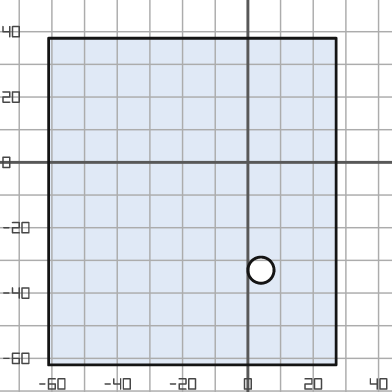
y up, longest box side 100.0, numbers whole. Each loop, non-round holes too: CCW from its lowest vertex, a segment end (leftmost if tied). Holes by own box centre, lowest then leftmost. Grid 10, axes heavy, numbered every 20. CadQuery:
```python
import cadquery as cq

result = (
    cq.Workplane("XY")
    .moveTo(-61.0, -62.0)
    .lineTo(27.0, -62.0)
    .lineTo(27.0, 38.0)
    .lineTo(-61.0, 38.0)
    .close()
    .moveTo(4.0, -33.0)
    .circle(4.0)
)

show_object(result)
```